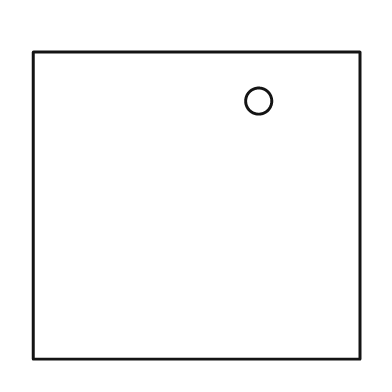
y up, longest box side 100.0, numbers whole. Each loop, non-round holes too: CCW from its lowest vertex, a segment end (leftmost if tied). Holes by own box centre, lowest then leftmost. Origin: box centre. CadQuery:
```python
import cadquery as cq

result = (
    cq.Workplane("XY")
    .moveTo(-50.0, -47.0)
    .lineTo(50.0, -47.0)
    .lineTo(50.0, 47.0)
    .lineTo(-50.0, 47.0)
    .close()
    .moveTo(19.0, 32.0)
    .circle(4.0)
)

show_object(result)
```